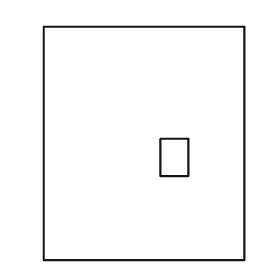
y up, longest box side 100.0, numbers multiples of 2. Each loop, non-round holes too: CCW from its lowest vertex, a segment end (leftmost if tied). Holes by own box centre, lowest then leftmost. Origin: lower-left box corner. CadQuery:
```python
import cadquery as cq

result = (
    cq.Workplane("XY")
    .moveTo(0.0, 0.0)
    .lineTo(86.0, 0.0)
    .lineTo(86.0, 100.0)
    .lineTo(0.0, 100.0)
    .close()
    .moveTo(50.0, 36.0)
    .lineTo(62.0, 36.0)
    .lineTo(62.0, 52.0)
    .lineTo(50.0, 52.0)
    .close()
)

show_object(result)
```